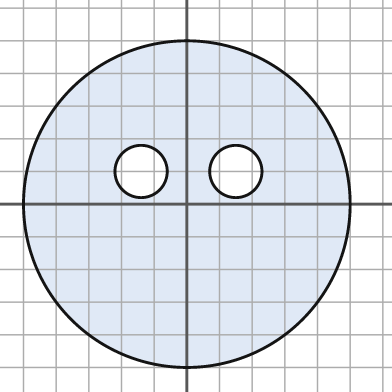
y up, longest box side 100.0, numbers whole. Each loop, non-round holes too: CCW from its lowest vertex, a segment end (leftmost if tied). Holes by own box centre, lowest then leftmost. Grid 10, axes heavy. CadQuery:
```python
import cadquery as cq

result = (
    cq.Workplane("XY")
    .moveTo(0.0, 0.0)
    .circle(50.0)
    .moveTo(-14.0, 10.0)
    .circle(8.0)
    .moveTo(15.0, 10.0)
    .circle(8.0)
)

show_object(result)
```